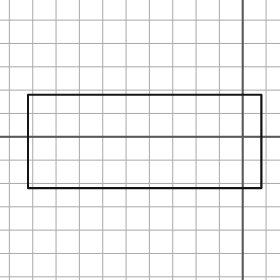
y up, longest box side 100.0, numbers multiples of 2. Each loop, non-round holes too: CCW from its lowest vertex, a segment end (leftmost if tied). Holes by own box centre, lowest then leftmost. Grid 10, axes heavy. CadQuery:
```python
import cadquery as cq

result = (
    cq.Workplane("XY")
    .moveTo(-92.0, -22.0)
    .lineTo(8.0, -22.0)
    .lineTo(8.0, 18.0)
    .lineTo(-92.0, 18.0)
    .close()
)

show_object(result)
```